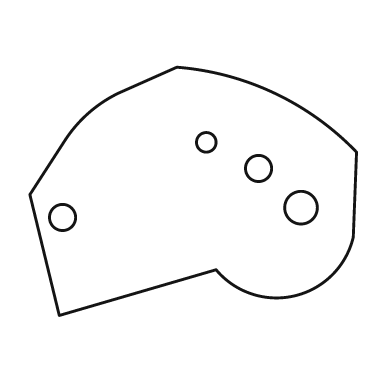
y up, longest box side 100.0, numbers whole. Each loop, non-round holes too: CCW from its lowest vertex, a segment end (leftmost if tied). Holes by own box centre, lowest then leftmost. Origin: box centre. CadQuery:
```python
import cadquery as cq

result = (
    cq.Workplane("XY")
    .moveTo(-41.0, -38.0)
    .lineTo(7.0, -24.0)
    .threePointArc((31.0, -32.0), (49.0, -14.0))
    .lineTo(50.0, 12.0)
    .threePointArc((25.0, 30.0), (-5.0, 38.0))
    .lineTo(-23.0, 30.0)
    .threePointArc((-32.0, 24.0), (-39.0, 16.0))
    .lineTo(-50.0, -1.0)
    .close()
    .moveTo(-40.0, -8.0)
    .circle(4.0)
    .moveTo(33.0, -5.0)
    .circle(5.0)
    .moveTo(20.0, 7.0)
    .circle(4.0)
    .moveTo(4.0, 15.0)
    .circle(3.0)
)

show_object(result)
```